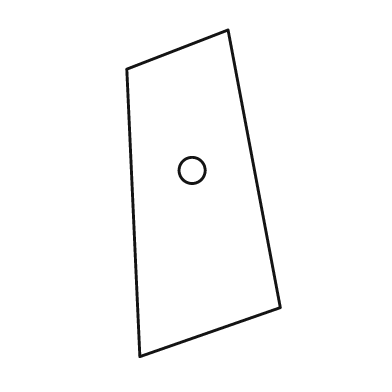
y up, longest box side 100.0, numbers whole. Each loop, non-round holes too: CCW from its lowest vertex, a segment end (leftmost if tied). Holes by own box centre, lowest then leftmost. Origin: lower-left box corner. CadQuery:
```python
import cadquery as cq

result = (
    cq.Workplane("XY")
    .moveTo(4.0, 0.0)
    .lineTo(47.0, 15.0)
    .lineTo(31.0, 100.0)
    .lineTo(0.0, 88.0)
    .close()
    .moveTo(20.0, 57.0)
    .circle(4.0)
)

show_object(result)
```